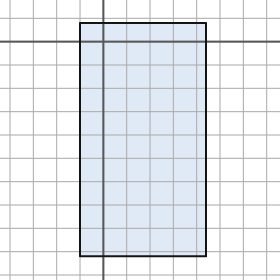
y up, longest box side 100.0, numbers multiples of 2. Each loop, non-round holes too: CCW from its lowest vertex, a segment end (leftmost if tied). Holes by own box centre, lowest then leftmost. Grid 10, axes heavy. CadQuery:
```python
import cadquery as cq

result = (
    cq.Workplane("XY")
    .moveTo(-10.0, -92.0)
    .lineTo(44.0, -92.0)
    .lineTo(44.0, 8.0)
    .lineTo(-10.0, 8.0)
    .close()
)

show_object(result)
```